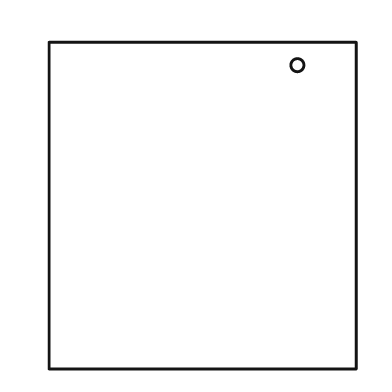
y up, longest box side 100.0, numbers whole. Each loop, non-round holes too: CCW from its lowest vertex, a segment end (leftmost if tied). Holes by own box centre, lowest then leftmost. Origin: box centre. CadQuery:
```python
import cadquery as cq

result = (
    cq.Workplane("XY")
    .moveTo(-47.0, -50.0)
    .lineTo(47.0, -50.0)
    .lineTo(47.0, 50.0)
    .lineTo(-47.0, 50.0)
    .close()
    .moveTo(29.0, 43.0)
    .circle(2.0)
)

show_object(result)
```